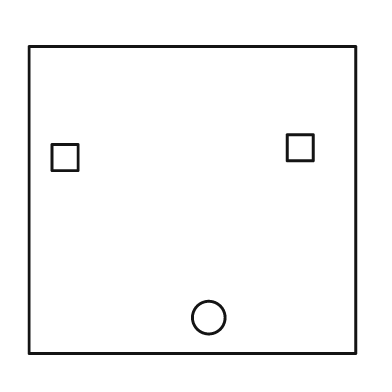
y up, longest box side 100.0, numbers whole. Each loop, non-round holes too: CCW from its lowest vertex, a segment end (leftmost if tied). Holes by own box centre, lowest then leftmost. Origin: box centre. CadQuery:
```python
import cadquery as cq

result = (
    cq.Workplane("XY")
    .moveTo(-50.0, -47.0)
    .lineTo(50.0, -47.0)
    .lineTo(50.0, 47.0)
    .lineTo(-50.0, 47.0)
    .close()
    .moveTo(5.0, -36.0)
    .circle(5.0)
    .moveTo(-43.0, 9.0)
    .lineTo(-35.0, 9.0)
    .lineTo(-35.0, 17.0)
    .lineTo(-43.0, 17.0)
    .close()
    .moveTo(29.0, 12.0)
    .lineTo(37.0, 12.0)
    .lineTo(37.0, 20.0)
    .lineTo(29.0, 20.0)
    .close()
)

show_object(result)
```